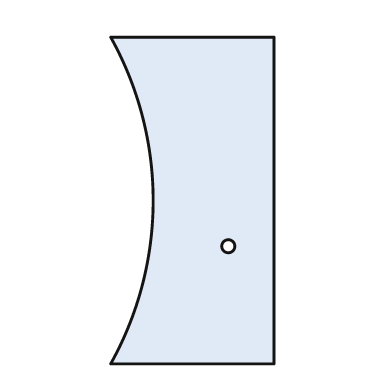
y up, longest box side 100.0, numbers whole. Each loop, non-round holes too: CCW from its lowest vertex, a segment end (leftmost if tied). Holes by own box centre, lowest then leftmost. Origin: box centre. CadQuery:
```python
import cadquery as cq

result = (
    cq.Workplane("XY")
    .moveTo(-25.0, -50.0)
    .lineTo(25.0, -50.0)
    .lineTo(25.0, 50.0)
    .lineTo(-25.0, 50.0)
    .threePointArc((-12.0, 0.0), (-25.0, -50.0))
    .close()
    .moveTo(11.0, -14.0)
    .circle(2.0)
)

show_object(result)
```